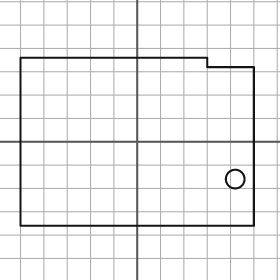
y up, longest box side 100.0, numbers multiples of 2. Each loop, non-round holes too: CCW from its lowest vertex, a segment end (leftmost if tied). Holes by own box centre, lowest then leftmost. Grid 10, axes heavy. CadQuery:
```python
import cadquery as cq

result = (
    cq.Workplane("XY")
    .moveTo(-50.0, -36.0)
    .lineTo(50.0, -36.0)
    .lineTo(50.0, 32.0)
    .lineTo(30.0, 32.0)
    .lineTo(30.0, 36.0)
    .lineTo(-50.0, 36.0)
    .close()
    .moveTo(42.0, -16.0)
    .circle(4.0)
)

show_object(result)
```